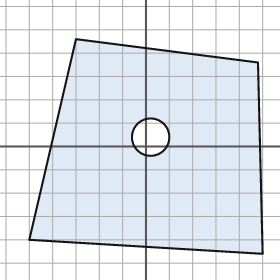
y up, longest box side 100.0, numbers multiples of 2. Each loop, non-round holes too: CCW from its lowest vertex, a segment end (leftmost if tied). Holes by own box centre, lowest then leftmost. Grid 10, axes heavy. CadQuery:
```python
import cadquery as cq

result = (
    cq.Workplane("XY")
    .moveTo(50.0, -46.0)
    .lineTo(48.0, 36.0)
    .lineTo(-30.0, 46.0)
    .lineTo(-50.0, -40.0)
    .close()
    .moveTo(2.0, 4.0)
    .circle(8.0)
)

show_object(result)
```